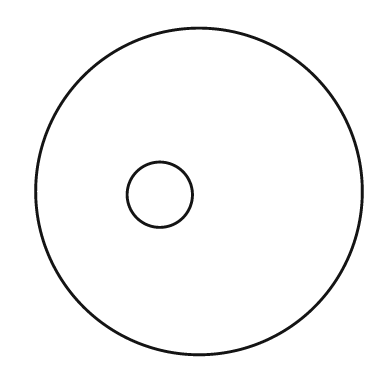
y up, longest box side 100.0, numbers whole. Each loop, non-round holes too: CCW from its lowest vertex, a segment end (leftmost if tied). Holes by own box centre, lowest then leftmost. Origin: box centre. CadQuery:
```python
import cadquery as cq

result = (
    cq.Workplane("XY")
    .moveTo(0.0, 0.0)
    .circle(50.0)
    .moveTo(-12.0, -1.0)
    .circle(10.0)
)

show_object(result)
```